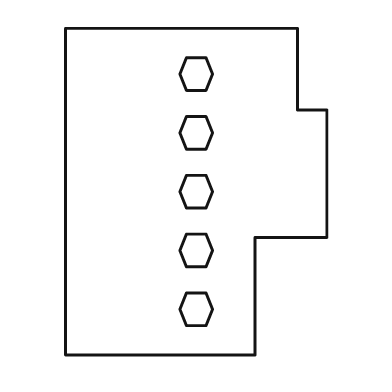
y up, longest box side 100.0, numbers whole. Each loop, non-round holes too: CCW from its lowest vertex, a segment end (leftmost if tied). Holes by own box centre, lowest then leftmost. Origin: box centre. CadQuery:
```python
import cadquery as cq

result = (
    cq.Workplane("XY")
    .moveTo(-40.0, -50.0)
    .lineTo(18.0, -50.0)
    .lineTo(18.0, -14.0)
    .lineTo(40.0, -14.0)
    .lineTo(40.0, 25.0)
    .lineTo(31.0, 25.0)
    .lineTo(31.0, 50.0)
    .lineTo(-40.0, 50.0)
    .close()
    .moveTo(-3.0, -41.0)
    .lineTo(3.0, -41.0)
    .lineTo(5.0, -36.0)
    .lineTo(3.0, -31.0)
    .lineTo(-3.0, -31.0)
    .lineTo(-5.0, -36.0)
    .close()
    .moveTo(-3.0, -23.0)
    .lineTo(3.0, -23.0)
    .lineTo(5.0, -18.0)
    .lineTo(3.0, -13.0)
    .lineTo(-3.0, -13.0)
    .lineTo(-5.0, -18.0)
    .close()
    .moveTo(-3.0, -5.0)
    .lineTo(3.0, -5.0)
    .lineTo(5.0, 0.0)
    .lineTo(3.0, 5.0)
    .lineTo(-3.0, 5.0)
    .lineTo(-5.0, 0.0)
    .close()
    .moveTo(-3.0, 13.0)
    .lineTo(3.0, 13.0)
    .lineTo(5.0, 18.0)
    .lineTo(3.0, 23.0)
    .lineTo(-3.0, 23.0)
    .lineTo(-5.0, 18.0)
    .close()
    .moveTo(-3.0, 31.0)
    .lineTo(3.0, 31.0)
    .lineTo(5.0, 36.0)
    .lineTo(3.0, 41.0)
    .lineTo(-3.0, 41.0)
    .lineTo(-5.0, 36.0)
    .close()
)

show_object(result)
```